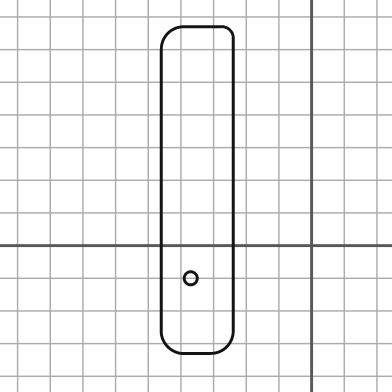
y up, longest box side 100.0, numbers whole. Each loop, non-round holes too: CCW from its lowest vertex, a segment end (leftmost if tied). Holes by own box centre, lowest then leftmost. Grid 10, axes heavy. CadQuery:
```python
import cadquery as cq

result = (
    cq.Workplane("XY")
    .moveTo(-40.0, -33.0)
    .lineTo(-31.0, -33.0)
    .threePointArc((-26.0, -31.0), (-24.0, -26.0))
    .lineTo(-24.0, 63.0)
    .threePointArc((-25.0, 66.0), (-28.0, 67.0))
    .lineTo(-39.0, 67.0)
    .threePointArc((-44.0, 65.0), (-46.0, 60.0))
    .lineTo(-46.0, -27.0)
    .threePointArc((-44.0, -31.0), (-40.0, -33.0))
    .close()
    .moveTo(-37.0, -10.0)
    .circle(2.0)
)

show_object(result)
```